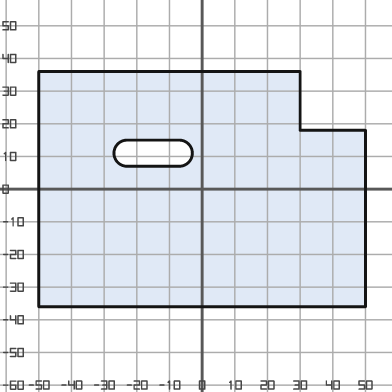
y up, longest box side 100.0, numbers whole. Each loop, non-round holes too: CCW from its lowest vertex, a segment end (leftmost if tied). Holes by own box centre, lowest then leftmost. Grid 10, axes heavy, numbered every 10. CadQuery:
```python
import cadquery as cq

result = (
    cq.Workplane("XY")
    .moveTo(-50.0, -36.0)
    .lineTo(50.0, -36.0)
    .lineTo(50.0, 18.0)
    .lineTo(30.0, 18.0)
    .lineTo(30.0, 36.0)
    .lineTo(-50.0, 36.0)
    .close()
    .moveTo(-23.0, 7.0)
    .lineTo(-7.0, 7.0)
    .threePointArc((-3.0, 11.0), (-7.0, 15.0))
    .lineTo(-23.0, 15.0)
    .threePointArc((-27.0, 11.0), (-23.0, 7.0))
    .close()
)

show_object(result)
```